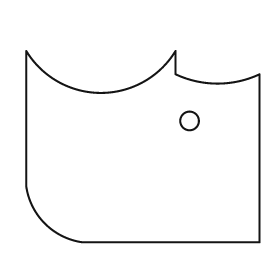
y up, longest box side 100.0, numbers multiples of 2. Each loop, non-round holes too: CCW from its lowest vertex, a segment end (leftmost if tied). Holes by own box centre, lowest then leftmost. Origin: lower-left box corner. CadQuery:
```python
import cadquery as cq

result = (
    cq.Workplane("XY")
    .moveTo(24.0, 0.0)
    .lineTo(100.0, 0.0)
    .lineTo(100.0, 72.0)
    .threePointArc((82.0, 68.0), (64.0, 72.0))
    .lineTo(64.0, 82.0)
    .threePointArc((32.0, 64.0), (0.0, 82.0))
    .lineTo(0.0, 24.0)
    .threePointArc((8.0, 8.0), (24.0, 0.0))
    .close()
    .moveTo(70.0, 52.0)
    .circle(4.0)
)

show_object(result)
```